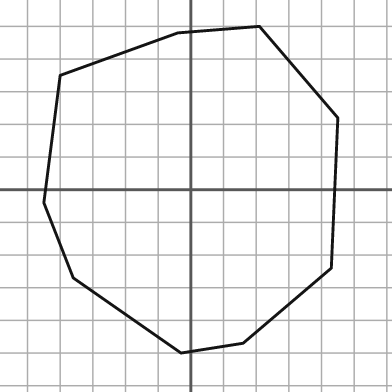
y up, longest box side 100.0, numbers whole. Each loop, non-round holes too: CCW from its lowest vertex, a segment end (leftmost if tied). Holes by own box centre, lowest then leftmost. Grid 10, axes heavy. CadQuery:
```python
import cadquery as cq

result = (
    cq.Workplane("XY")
    .moveTo(-3.0, -50.0)
    .lineTo(16.0, -47.0)
    .lineTo(43.0, -24.0)
    .lineTo(45.0, 22.0)
    .lineTo(21.0, 50.0)
    .lineTo(-4.0, 48.0)
    .lineTo(-40.0, 35.0)
    .lineTo(-45.0, -4.0)
    .lineTo(-36.0, -27.0)
    .close()
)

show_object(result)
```